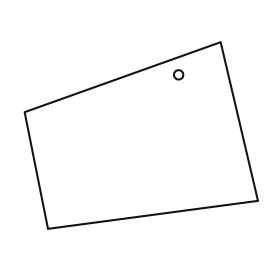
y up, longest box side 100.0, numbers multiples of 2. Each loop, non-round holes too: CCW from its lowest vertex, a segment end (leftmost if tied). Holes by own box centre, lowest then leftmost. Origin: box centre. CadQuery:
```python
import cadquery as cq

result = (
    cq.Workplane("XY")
    .moveTo(-40.0, -40.0)
    .lineTo(50.0, -28.0)
    .lineTo(34.0, 40.0)
    .lineTo(-50.0, 10.0)
    .close()
    .moveTo(16.0, 26.0)
    .circle(2.0)
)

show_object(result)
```